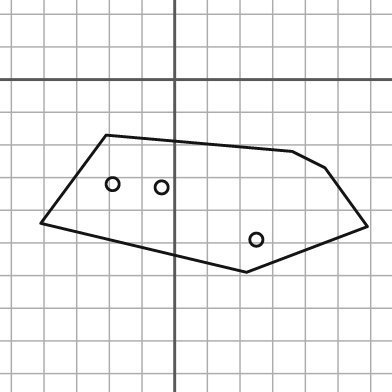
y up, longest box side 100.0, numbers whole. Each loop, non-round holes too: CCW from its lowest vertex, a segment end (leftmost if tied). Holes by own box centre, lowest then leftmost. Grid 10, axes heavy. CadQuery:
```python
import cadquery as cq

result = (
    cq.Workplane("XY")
    .moveTo(22.0, -59.0)
    .lineTo(59.0, -45.0)
    .lineTo(46.0, -27.0)
    .lineTo(36.0, -22.0)
    .lineTo(-21.0, -17.0)
    .lineTo(-41.0, -44.0)
    .close()
    .moveTo(25.0, -49.0)
    .circle(2.0)
    .moveTo(-4.0, -33.0)
    .circle(2.0)
    .moveTo(-19.0, -32.0)
    .circle(2.0)
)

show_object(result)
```